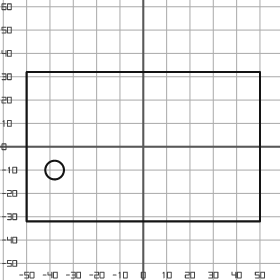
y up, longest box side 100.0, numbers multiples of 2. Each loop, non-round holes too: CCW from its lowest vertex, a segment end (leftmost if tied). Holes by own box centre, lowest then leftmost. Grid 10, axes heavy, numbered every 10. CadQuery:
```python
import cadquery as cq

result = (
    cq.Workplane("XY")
    .moveTo(-50.0, -32.0)
    .lineTo(50.0, -32.0)
    .lineTo(50.0, 32.0)
    .lineTo(-50.0, 32.0)
    .close()
    .moveTo(-38.0, -10.0)
    .circle(4.0)
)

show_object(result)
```